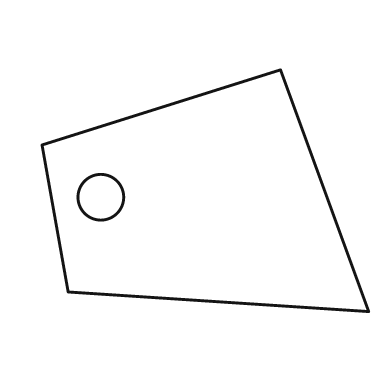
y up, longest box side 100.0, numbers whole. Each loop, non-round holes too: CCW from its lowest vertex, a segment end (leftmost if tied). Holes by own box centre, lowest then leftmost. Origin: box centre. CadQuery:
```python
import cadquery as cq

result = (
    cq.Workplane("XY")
    .moveTo(50.0, -37.0)
    .lineTo(23.0, 37.0)
    .lineTo(-50.0, 14.0)
    .lineTo(-42.0, -31.0)
    .close()
    .moveTo(-32.0, -2.0)
    .circle(7.0)
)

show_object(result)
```